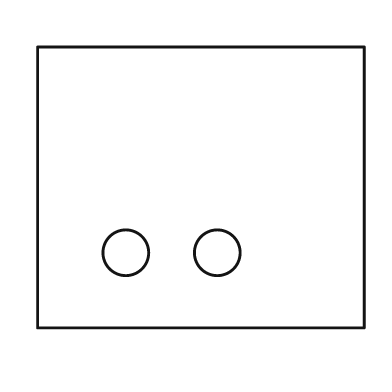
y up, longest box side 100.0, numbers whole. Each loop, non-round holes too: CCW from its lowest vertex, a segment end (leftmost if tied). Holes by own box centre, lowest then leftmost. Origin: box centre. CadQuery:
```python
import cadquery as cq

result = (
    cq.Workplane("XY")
    .moveTo(-50.0, -43.0)
    .lineTo(50.0, -43.0)
    .lineTo(50.0, 43.0)
    .lineTo(-50.0, 43.0)
    .close()
    .moveTo(-23.0, -20.0)
    .circle(7.0)
    .moveTo(5.0, -20.0)
    .circle(7.0)
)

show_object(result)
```